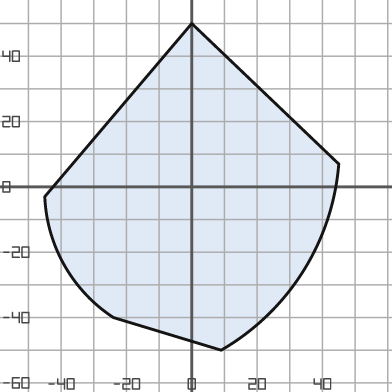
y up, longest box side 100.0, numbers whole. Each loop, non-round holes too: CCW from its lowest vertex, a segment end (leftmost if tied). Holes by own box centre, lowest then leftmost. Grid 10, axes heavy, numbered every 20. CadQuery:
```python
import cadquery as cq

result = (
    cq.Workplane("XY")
    .moveTo(9.0, -50.0)
    .threePointArc((34.0, -26.0), (45.0, 7.0))
    .lineTo(0.0, 50.0)
    .lineTo(-45.0, -3.0)
    .threePointArc((-39.0, -24.0), (-24.0, -40.0))
    .close()
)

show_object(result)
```